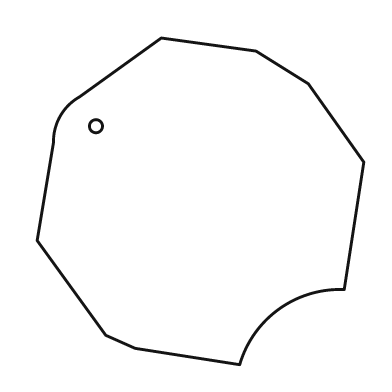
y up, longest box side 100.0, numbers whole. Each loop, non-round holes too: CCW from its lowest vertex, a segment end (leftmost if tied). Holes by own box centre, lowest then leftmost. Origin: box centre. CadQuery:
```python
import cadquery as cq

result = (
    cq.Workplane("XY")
    .moveTo(12.0, -50.0)
    .threePointArc((24.0, -33.0), (44.0, -27.0))
    .lineTo(50.0, 12.0)
    .lineTo(33.0, 36.0)
    .lineTo(17.0, 46.0)
    .lineTo(-12.0, 50.0)
    .lineTo(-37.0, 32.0)
    .threePointArc((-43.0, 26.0), (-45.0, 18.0))
    .lineTo(-50.0, -12.0)
    .lineTo(-29.0, -41.0)
    .lineTo(-20.0, -45.0)
    .close()
    .moveTo(-32.0, 23.0)
    .circle(2.0)
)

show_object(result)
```